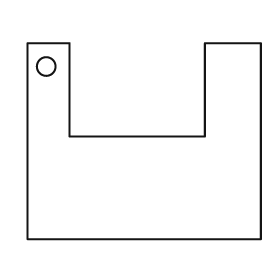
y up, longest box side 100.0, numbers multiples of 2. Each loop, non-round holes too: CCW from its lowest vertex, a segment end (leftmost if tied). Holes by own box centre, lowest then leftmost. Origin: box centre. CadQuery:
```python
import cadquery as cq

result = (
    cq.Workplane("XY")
    .moveTo(-50.0, -42.0)
    .lineTo(50.0, -42.0)
    .lineTo(50.0, 42.0)
    .lineTo(26.0, 42.0)
    .lineTo(26.0, 2.0)
    .lineTo(-32.0, 2.0)
    .lineTo(-32.0, 42.0)
    .lineTo(-50.0, 42.0)
    .close()
    .moveTo(-42.0, 32.0)
    .circle(4.0)
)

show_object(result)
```